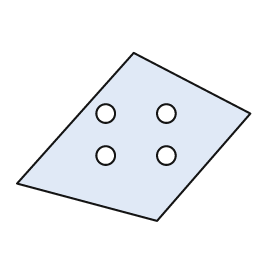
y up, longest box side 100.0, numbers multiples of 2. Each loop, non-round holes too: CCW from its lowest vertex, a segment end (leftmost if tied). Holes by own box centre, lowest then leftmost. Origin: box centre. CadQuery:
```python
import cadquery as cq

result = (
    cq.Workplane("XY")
    .moveTo(10.0, -36.0)
    .lineTo(50.0, 10.0)
    .lineTo(0.0, 36.0)
    .lineTo(-50.0, -20.0)
    .close()
    .moveTo(-12.0, -8.0)
    .circle(4.0)
    .moveTo(14.0, -8.0)
    .circle(4.0)
    .moveTo(-12.0, 10.0)
    .circle(4.0)
    .moveTo(14.0, 10.0)
    .circle(4.0)
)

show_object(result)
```